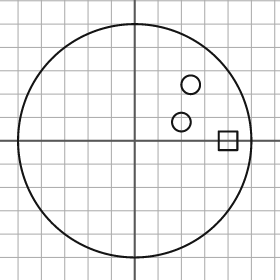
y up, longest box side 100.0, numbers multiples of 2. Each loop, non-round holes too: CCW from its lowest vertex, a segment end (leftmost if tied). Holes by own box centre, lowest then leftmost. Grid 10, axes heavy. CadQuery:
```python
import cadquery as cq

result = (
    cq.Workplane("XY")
    .moveTo(0.0, 0.0)
    .circle(50.0)
    .moveTo(36.0, -4.0)
    .lineTo(44.0, -4.0)
    .lineTo(44.0, 4.0)
    .lineTo(36.0, 4.0)
    .close()
    .moveTo(20.0, 8.0)
    .circle(4.0)
    .moveTo(24.0, 24.0)
    .circle(4.0)
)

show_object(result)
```